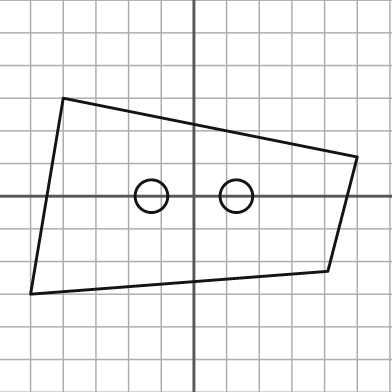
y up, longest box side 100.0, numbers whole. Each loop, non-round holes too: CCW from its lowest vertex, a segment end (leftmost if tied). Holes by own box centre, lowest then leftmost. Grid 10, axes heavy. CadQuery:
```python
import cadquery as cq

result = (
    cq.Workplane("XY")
    .moveTo(-50.0, -30.0)
    .lineTo(41.0, -23.0)
    .lineTo(50.0, 12.0)
    .lineTo(-40.0, 30.0)
    .close()
    .moveTo(-13.0, 0.0)
    .circle(5.0)
    .moveTo(13.0, 0.0)
    .circle(5.0)
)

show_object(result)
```